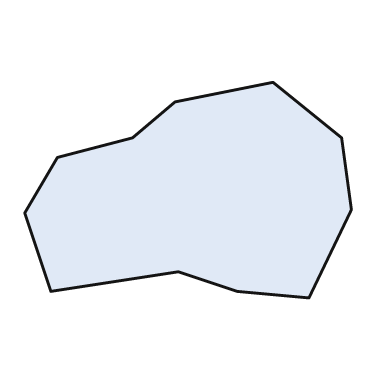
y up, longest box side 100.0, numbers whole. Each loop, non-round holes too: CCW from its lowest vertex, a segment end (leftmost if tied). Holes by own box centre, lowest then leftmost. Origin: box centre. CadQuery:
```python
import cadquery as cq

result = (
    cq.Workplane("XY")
    .moveTo(37.0, -33.0)
    .lineTo(50.0, -6.0)
    .lineTo(47.0, 16.0)
    .lineTo(26.0, 33.0)
    .lineTo(-4.0, 27.0)
    .lineTo(-17.0, 16.0)
    .lineTo(-40.0, 10.0)
    .lineTo(-50.0, -7.0)
    .lineTo(-42.0, -31.0)
    .lineTo(-3.0, -25.0)
    .lineTo(15.0, -31.0)
    .close()
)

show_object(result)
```